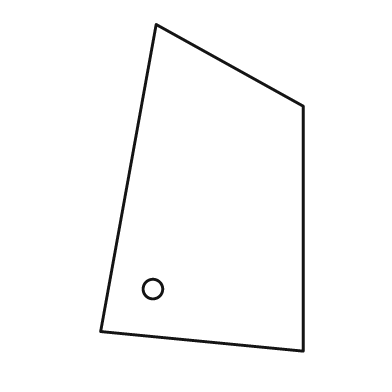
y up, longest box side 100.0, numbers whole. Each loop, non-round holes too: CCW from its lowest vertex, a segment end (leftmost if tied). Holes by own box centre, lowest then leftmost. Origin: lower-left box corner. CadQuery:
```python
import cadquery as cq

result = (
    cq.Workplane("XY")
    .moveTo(62.0, 0.0)
    .lineTo(62.0, 75.0)
    .lineTo(17.0, 100.0)
    .lineTo(0.0, 6.0)
    .close()
    .moveTo(16.0, 19.0)
    .circle(3.0)
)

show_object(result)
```